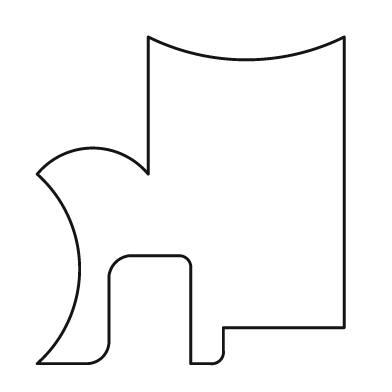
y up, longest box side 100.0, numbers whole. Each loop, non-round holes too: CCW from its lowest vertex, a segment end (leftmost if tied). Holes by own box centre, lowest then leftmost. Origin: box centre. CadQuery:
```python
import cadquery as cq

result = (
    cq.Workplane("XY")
    .moveTo(-47.0, -50.0)
    .lineTo(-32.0, -50.0)
    .threePointArc((-27.0, -48.0), (-25.0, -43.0))
    .lineTo(-25.0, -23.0)
    .threePointArc((-23.0, -19.0), (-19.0, -17.0))
    .lineTo(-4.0, -17.0)
    .threePointArc((-1.0, -18.0), (0.0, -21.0))
    .lineTo(0.0, -50.0)
    .lineTo(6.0, -50.0)
    .threePointArc((9.0, -49.0), (10.0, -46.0))
    .lineTo(10.0, -39.0)
    .lineTo(47.0, -39.0)
    .lineTo(47.0, 50.0)
    .threePointArc((17.0, 43.0), (-13.0, 50.0))
    .lineTo(-13.0, 8.0)
    .threePointArc((-30.0, 16.0), (-47.0, 8.0))
    .threePointArc((-34.0, -21.0), (-47.0, -50.0))
    .close()
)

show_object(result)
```